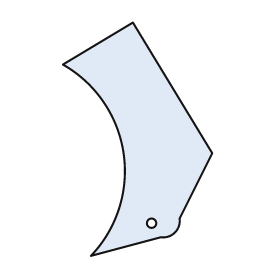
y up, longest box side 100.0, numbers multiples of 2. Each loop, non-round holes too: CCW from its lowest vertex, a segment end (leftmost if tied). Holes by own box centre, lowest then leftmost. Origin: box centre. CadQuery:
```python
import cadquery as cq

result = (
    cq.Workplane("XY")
    .moveTo(-20.0, -50.0)
    .lineTo(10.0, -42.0)
    .threePointArc((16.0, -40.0), (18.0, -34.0))
    .lineTo(32.0, -6.0)
    .lineTo(-2.0, 50.0)
    .lineTo(-32.0, 32.0)
    .threePointArc((-6.0, -6.0), (-20.0, -50.0))
    .close()
    .moveTo(6.0, -36.0)
    .circle(2.0)
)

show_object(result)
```